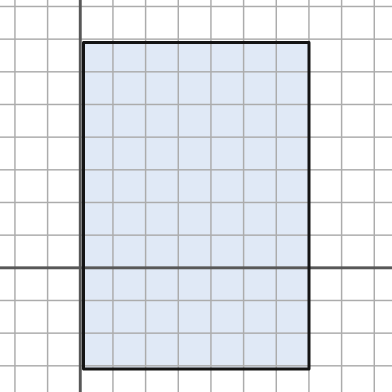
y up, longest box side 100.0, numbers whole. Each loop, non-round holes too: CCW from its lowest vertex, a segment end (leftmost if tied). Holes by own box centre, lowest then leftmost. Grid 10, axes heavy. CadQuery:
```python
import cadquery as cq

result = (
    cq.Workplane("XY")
    .moveTo(1.0, -31.0)
    .lineTo(70.0, -31.0)
    .lineTo(70.0, 69.0)
    .lineTo(1.0, 69.0)
    .close()
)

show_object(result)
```